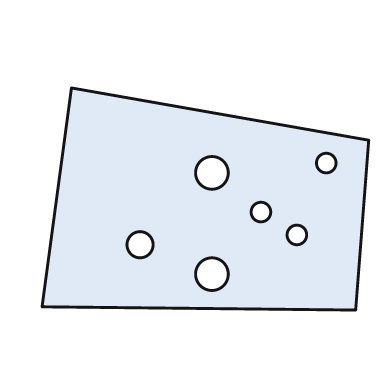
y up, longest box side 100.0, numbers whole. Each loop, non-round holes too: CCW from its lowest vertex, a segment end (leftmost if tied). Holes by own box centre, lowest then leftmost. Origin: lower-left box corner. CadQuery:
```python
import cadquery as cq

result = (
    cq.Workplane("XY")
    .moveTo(96.0, 0.0)
    .lineTo(100.0, 52.0)
    .lineTo(9.0, 68.0)
    .lineTo(0.0, 1.0)
    .close()
    .moveTo(52.0, 11.0)
    .circle(5.0)
    .moveTo(30.0, 20.0)
    .circle(4.0)
    .moveTo(78.0, 23.0)
    .circle(3.0)
    .moveTo(67.0, 30.0)
    .circle(3.0)
    .moveTo(52.0, 42.0)
    .circle(5.0)
    .moveTo(87.0, 45.0)
    .circle(3.0)
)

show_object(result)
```